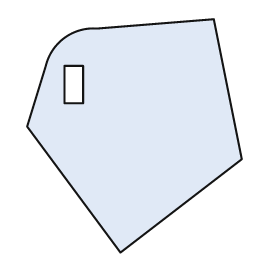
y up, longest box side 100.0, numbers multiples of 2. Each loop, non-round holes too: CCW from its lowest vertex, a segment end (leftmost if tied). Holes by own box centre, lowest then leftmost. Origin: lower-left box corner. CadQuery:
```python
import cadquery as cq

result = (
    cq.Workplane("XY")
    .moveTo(40.0, 0.0)
    .lineTo(92.0, 40.0)
    .lineTo(80.0, 100.0)
    .lineTo(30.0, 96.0)
    .threePointArc((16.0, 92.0), (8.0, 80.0))
    .lineTo(0.0, 54.0)
    .close()
    .moveTo(16.0, 64.0)
    .lineTo(24.0, 64.0)
    .lineTo(24.0, 80.0)
    .lineTo(16.0, 80.0)
    .close()
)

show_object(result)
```